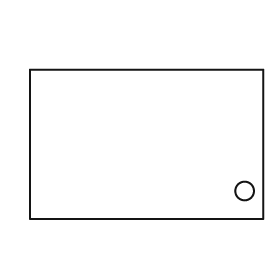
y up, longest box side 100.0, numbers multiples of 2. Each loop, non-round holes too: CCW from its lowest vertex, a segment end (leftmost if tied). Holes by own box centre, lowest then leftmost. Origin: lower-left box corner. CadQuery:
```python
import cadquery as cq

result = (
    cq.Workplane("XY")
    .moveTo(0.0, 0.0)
    .lineTo(100.0, 0.0)
    .lineTo(100.0, 64.0)
    .lineTo(0.0, 64.0)
    .close()
    .moveTo(92.0, 12.0)
    .circle(4.0)
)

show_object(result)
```